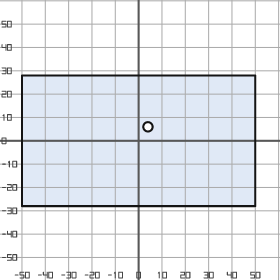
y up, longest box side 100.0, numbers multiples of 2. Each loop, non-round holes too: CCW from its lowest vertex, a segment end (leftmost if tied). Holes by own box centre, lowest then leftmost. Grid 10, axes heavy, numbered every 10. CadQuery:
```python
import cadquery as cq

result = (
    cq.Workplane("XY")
    .moveTo(-50.0, -28.0)
    .lineTo(50.0, -28.0)
    .lineTo(50.0, 28.0)
    .lineTo(-50.0, 28.0)
    .close()
    .moveTo(4.0, 6.0)
    .circle(2.0)
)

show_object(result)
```